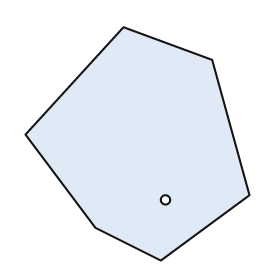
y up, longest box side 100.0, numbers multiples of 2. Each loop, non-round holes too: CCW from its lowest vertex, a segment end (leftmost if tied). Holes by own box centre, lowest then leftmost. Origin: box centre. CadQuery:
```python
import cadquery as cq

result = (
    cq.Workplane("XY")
    .moveTo(10.0, -50.0)
    .lineTo(48.0, -22.0)
    .lineTo(32.0, 36.0)
    .lineTo(-6.0, 50.0)
    .lineTo(-48.0, 4.0)
    .lineTo(-18.0, -36.0)
    .close()
    .moveTo(12.0, -24.0)
    .circle(2.0)
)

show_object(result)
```